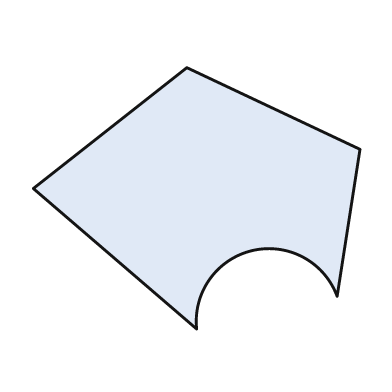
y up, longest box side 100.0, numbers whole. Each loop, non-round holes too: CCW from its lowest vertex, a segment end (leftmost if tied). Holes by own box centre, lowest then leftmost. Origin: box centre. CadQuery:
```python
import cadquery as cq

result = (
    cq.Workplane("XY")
    .moveTo(0.0, -40.0)
    .threePointArc((17.0, -16.0), (43.0, -30.0))
    .lineTo(50.0, 15.0)
    .lineTo(-3.0, 40.0)
    .lineTo(-50.0, 3.0)
    .close()
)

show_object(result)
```